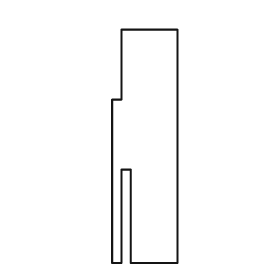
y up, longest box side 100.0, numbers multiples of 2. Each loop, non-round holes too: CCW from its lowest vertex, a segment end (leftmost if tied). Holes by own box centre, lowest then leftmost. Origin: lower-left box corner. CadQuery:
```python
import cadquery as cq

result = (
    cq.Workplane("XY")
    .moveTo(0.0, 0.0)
    .lineTo(4.0, 0.0)
    .lineTo(4.0, 40.0)
    .lineTo(8.0, 40.0)
    .lineTo(8.0, 0.0)
    .lineTo(28.0, 0.0)
    .lineTo(28.0, 100.0)
    .lineTo(4.0, 100.0)
    .lineTo(4.0, 70.0)
    .lineTo(0.0, 70.0)
    .close()
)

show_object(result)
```